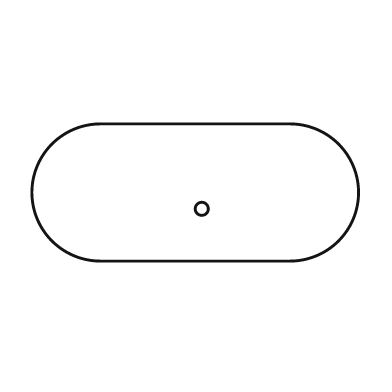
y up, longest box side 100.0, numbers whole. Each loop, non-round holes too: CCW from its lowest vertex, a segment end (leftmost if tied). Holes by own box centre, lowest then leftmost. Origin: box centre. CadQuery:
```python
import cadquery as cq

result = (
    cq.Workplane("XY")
    .moveTo(-29.0, -21.0)
    .lineTo(29.0, -21.0)
    .threePointArc((50.0, 0.0), (29.0, 21.0))
    .lineTo(-29.0, 21.0)
    .threePointArc((-50.0, 0.0), (-29.0, -21.0))
    .close()
    .moveTo(2.0, -5.0)
    .circle(2.0)
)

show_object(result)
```